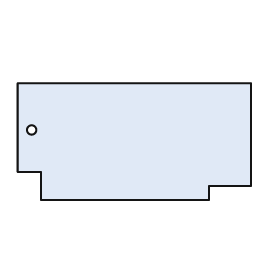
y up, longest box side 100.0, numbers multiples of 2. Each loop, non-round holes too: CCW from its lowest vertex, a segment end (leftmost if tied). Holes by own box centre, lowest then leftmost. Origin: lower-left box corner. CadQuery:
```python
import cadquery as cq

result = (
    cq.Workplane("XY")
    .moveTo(10.0, 0.0)
    .lineTo(82.0, 0.0)
    .lineTo(82.0, 6.0)
    .lineTo(100.0, 6.0)
    .lineTo(100.0, 50.0)
    .lineTo(0.0, 50.0)
    .lineTo(0.0, 12.0)
    .lineTo(10.0, 12.0)
    .close()
    .moveTo(6.0, 30.0)
    .circle(2.0)
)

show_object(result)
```